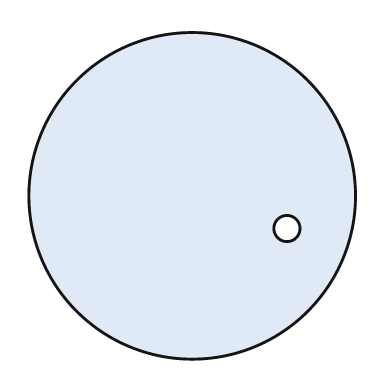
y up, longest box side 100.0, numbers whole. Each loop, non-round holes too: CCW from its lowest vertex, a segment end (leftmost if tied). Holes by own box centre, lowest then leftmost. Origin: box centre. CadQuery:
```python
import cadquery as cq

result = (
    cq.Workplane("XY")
    .moveTo(0.0, 0.0)
    .circle(50.0)
    .moveTo(29.0, -10.0)
    .circle(4.0)
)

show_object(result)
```